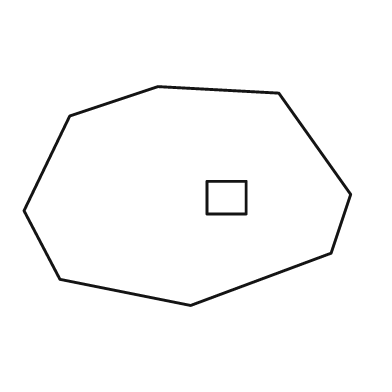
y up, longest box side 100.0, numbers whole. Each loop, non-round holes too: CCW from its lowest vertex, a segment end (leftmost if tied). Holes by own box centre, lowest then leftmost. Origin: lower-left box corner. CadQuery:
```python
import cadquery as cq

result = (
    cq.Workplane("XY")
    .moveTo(51.0, 0.0)
    .lineTo(94.0, 16.0)
    .lineTo(100.0, 34.0)
    .lineTo(78.0, 65.0)
    .lineTo(41.0, 67.0)
    .lineTo(14.0, 58.0)
    .lineTo(0.0, 29.0)
    .lineTo(11.0, 8.0)
    .close()
    .moveTo(56.0, 28.0)
    .lineTo(68.0, 28.0)
    .lineTo(68.0, 38.0)
    .lineTo(56.0, 38.0)
    .close()
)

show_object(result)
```